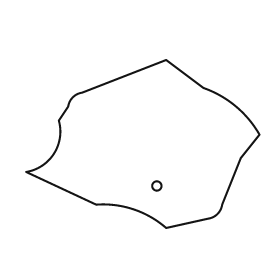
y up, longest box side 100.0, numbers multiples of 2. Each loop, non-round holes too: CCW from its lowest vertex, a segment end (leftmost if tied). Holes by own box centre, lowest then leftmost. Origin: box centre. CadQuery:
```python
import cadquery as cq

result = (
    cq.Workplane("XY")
    .moveTo(10.0, -36.0)
    .lineTo(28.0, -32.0)
    .threePointArc((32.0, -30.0), (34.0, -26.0))
    .lineTo(42.0, -6.0)
    .lineTo(50.0, 4.0)
    .threePointArc((40.0, 16.0), (26.0, 24.0))
    .lineTo(10.0, 36.0)
    .lineTo(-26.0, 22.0)
    .threePointArc((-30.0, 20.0), (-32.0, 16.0))
    .lineTo(-36.0, 10.0)
    .threePointArc((-38.0, -4.0), (-50.0, -12.0))
    .lineTo(-20.0, -26.0)
    .threePointArc((-4.0, -28.0), (10.0, -36.0))
    .close()
    .moveTo(6.0, -18.0)
    .circle(2.0)
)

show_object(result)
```